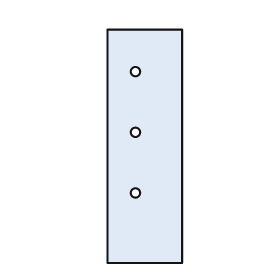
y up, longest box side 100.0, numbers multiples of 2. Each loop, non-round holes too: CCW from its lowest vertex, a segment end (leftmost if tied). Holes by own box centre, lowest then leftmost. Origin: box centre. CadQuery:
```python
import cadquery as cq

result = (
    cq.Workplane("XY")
    .moveTo(-16.0, -50.0)
    .lineTo(16.0, -50.0)
    .lineTo(16.0, 50.0)
    .lineTo(-16.0, 50.0)
    .close()
    .moveTo(-4.0, -20.0)
    .circle(2.0)
    .moveTo(-4.0, 6.0)
    .circle(2.0)
    .moveTo(-4.0, 32.0)
    .circle(2.0)
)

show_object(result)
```